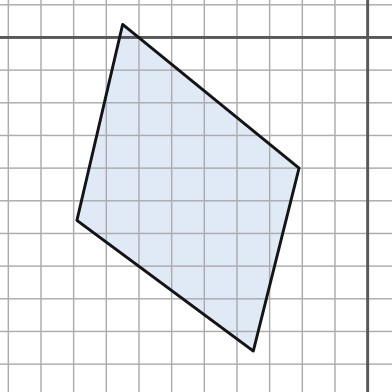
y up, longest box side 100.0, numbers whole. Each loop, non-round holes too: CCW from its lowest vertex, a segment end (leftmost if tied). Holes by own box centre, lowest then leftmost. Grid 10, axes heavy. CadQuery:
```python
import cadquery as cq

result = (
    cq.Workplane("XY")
    .moveTo(-35.0, -96.0)
    .lineTo(-21.0, -40.0)
    .lineTo(-75.0, 4.0)
    .lineTo(-89.0, -56.0)
    .close()
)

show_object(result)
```